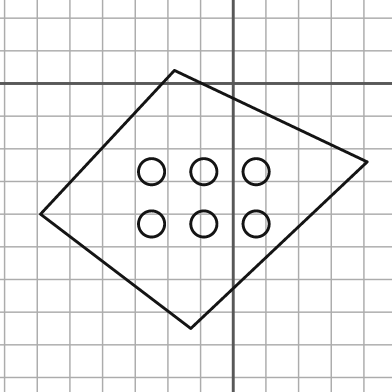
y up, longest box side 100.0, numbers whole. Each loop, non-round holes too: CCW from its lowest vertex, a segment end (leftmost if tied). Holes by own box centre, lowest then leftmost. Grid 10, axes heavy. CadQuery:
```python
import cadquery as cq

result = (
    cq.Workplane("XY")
    .moveTo(-13.0, -75.0)
    .lineTo(41.0, -24.0)
    .lineTo(-18.0, 4.0)
    .lineTo(-59.0, -40.0)
    .close()
    .moveTo(-25.0, -43.0)
    .circle(4.0)
    .moveTo(-9.0, -43.0)
    .circle(4.0)
    .moveTo(7.0, -43.0)
    .circle(4.0)
    .moveTo(-25.0, -27.0)
    .circle(4.0)
    .moveTo(-9.0, -27.0)
    .circle(4.0)
    .moveTo(7.0, -27.0)
    .circle(4.0)
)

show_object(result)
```